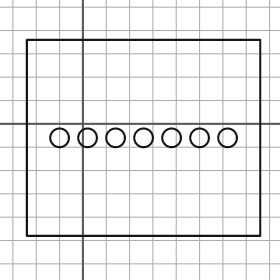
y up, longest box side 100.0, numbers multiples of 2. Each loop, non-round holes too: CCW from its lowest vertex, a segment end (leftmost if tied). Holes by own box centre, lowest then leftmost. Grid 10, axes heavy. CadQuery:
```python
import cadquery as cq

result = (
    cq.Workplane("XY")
    .moveTo(-24.0, -48.0)
    .lineTo(76.0, -48.0)
    .lineTo(76.0, 36.0)
    .lineTo(-24.0, 36.0)
    .close()
    .moveTo(-10.0, -6.0)
    .circle(4.0)
    .moveTo(2.0, -6.0)
    .circle(4.0)
    .moveTo(14.0, -6.0)
    .circle(4.0)
    .moveTo(26.0, -6.0)
    .circle(4.0)
    .moveTo(38.0, -6.0)
    .circle(4.0)
    .moveTo(50.0, -6.0)
    .circle(4.0)
    .moveTo(62.0, -6.0)
    .circle(4.0)
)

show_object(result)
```